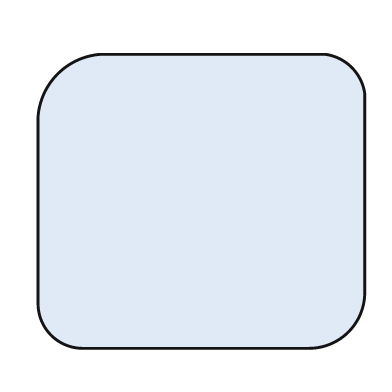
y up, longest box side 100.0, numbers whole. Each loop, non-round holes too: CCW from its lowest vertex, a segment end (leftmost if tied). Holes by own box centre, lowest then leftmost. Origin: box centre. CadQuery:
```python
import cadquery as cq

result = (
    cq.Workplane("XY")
    .moveTo(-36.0, -45.0)
    .lineTo(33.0, -45.0)
    .threePointArc((45.0, -40.0), (50.0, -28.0))
    .lineTo(50.0, 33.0)
    .threePointArc((46.0, 41.0), (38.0, 45.0))
    .lineTo(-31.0, 45.0)
    .threePointArc((-44.0, 39.0), (-50.0, 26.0))
    .lineTo(-50.0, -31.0)
    .threePointArc((-46.0, -41.0), (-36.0, -45.0))
    .close()
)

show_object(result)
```